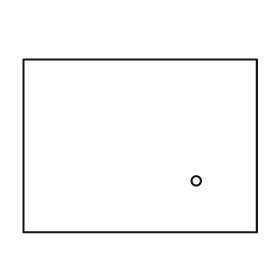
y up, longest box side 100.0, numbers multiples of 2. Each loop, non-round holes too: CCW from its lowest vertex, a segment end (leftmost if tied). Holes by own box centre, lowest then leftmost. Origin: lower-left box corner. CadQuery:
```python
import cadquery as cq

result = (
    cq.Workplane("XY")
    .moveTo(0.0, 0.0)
    .lineTo(100.0, 0.0)
    .lineTo(100.0, 74.0)
    .lineTo(0.0, 74.0)
    .close()
    .moveTo(74.0, 22.0)
    .circle(2.0)
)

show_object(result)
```